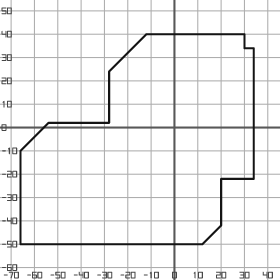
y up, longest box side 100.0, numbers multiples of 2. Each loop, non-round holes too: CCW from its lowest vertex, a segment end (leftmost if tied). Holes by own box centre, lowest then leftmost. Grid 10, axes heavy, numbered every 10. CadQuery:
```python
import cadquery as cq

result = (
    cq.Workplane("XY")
    .moveTo(-66.0, -50.0)
    .lineTo(12.0, -50.0)
    .lineTo(20.0, -42.0)
    .lineTo(20.0, -22.0)
    .lineTo(34.0, -22.0)
    .lineTo(34.0, 34.0)
    .lineTo(30.0, 34.0)
    .lineTo(30.0, 40.0)
    .lineTo(-12.0, 40.0)
    .lineTo(-28.0, 24.0)
    .lineTo(-28.0, 2.0)
    .lineTo(-54.0, 2.0)
    .lineTo(-66.0, -10.0)
    .close()
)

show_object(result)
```